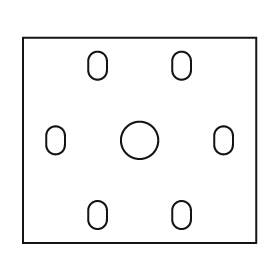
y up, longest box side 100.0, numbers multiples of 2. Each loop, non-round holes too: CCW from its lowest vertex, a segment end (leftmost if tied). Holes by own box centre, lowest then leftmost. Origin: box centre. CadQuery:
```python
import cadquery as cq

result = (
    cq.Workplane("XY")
    .moveTo(-50.0, -44.0)
    .lineTo(50.0, -44.0)
    .lineTo(50.0, 44.0)
    .lineTo(-50.0, 44.0)
    .close()
    .moveTo(-22.0, -34.0)
    .threePointArc((-18.0, -38.0), (-14.0, -34.0))
    .lineTo(-14.0, -30.0)
    .threePointArc((-18.0, -26.0), (-22.0, -30.0))
    .close()
    .moveTo(14.0, -34.0)
    .threePointArc((18.0, -38.0), (22.0, -34.0))
    .lineTo(22.0, -30.0)
    .threePointArc((18.0, -26.0), (14.0, -30.0))
    .close()
    .moveTo(-40.0, -2.0)
    .threePointArc((-36.0, -6.0), (-32.0, -2.0))
    .lineTo(-32.0, 2.0)
    .threePointArc((-36.0, 6.0), (-40.0, 2.0))
    .close()
    .moveTo(0.0, 0.0)
    .circle(8.0)
    .moveTo(32.0, -2.0)
    .threePointArc((36.0, -6.0), (40.0, -2.0))
    .lineTo(40.0, 2.0)
    .threePointArc((36.0, 6.0), (32.0, 2.0))
    .close()
    .moveTo(-22.0, 30.0)
    .threePointArc((-18.0, 26.0), (-14.0, 30.0))
    .lineTo(-14.0, 34.0)
    .threePointArc((-18.0, 38.0), (-22.0, 34.0))
    .close()
    .moveTo(14.0, 30.0)
    .threePointArc((18.0, 26.0), (22.0, 30.0))
    .lineTo(22.0, 34.0)
    .threePointArc((18.0, 38.0), (14.0, 34.0))
    .close()
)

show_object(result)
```